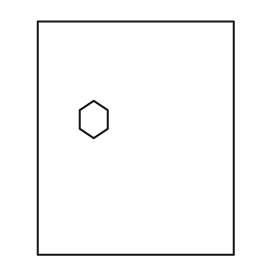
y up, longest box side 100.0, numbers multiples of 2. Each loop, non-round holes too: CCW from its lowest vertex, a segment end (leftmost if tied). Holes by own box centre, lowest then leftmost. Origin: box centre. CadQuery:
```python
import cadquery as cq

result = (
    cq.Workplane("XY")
    .moveTo(-42.0, -50.0)
    .lineTo(42.0, -50.0)
    .lineTo(42.0, 50.0)
    .lineTo(-42.0, 50.0)
    .close()
    .moveTo(-18.0, 0.0)
    .lineTo(-12.0, 4.0)
    .lineTo(-12.0, 12.0)
    .lineTo(-18.0, 16.0)
    .lineTo(-24.0, 12.0)
    .lineTo(-24.0, 4.0)
    .close()
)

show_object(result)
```